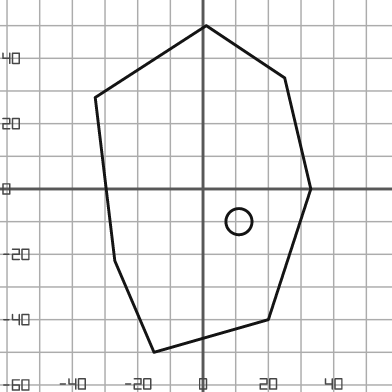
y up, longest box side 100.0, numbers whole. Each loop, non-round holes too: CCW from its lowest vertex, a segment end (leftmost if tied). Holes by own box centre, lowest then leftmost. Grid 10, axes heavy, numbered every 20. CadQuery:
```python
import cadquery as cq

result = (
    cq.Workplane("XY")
    .moveTo(-15.0, -50.0)
    .lineTo(20.0, -40.0)
    .lineTo(33.0, 0.0)
    .lineTo(25.0, 34.0)
    .lineTo(1.0, 50.0)
    .lineTo(-33.0, 28.0)
    .lineTo(-27.0, -22.0)
    .close()
    .moveTo(11.0, -10.0)
    .circle(4.0)
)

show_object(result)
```